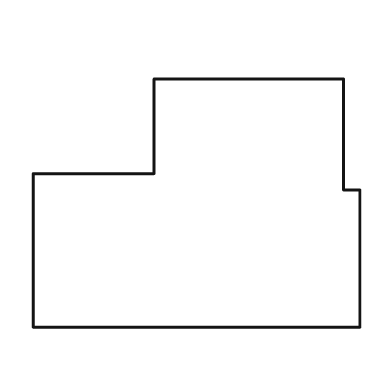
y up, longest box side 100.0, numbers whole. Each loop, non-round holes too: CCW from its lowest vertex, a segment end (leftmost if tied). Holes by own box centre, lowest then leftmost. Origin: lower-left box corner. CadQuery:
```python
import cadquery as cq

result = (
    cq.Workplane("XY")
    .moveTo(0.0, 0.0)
    .lineTo(100.0, 0.0)
    .lineTo(100.0, 42.0)
    .lineTo(95.0, 42.0)
    .lineTo(95.0, 76.0)
    .lineTo(37.0, 76.0)
    .lineTo(37.0, 47.0)
    .lineTo(0.0, 47.0)
    .close()
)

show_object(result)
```